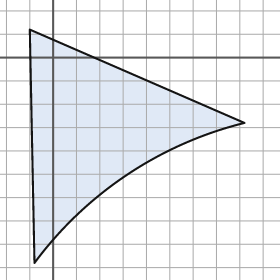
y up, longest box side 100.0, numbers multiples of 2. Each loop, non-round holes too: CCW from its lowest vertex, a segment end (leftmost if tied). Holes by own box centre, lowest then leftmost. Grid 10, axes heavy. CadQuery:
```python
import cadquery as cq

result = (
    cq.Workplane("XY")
    .moveTo(-8.0, -88.0)
    .threePointArc((32.0, -50.0), (82.0, -28.0))
    .lineTo(-10.0, 12.0)
    .close()
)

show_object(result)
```